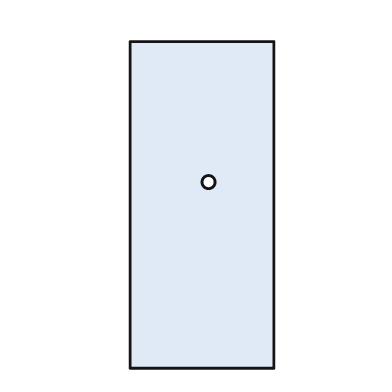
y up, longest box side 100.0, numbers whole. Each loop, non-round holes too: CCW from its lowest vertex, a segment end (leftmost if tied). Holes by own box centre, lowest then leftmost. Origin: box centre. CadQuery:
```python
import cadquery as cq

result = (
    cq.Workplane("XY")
    .moveTo(-22.0, -50.0)
    .lineTo(22.0, -50.0)
    .lineTo(22.0, 50.0)
    .lineTo(-22.0, 50.0)
    .close()
    .moveTo(2.0, 7.0)
    .circle(2.0)
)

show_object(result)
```